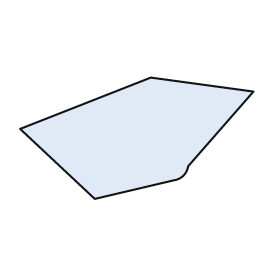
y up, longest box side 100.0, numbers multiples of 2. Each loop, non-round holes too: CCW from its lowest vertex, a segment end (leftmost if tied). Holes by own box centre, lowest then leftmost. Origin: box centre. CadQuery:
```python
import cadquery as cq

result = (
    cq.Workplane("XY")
    .moveTo(-18.0, -26.0)
    .lineTo(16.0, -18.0)
    .threePointArc((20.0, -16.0), (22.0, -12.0))
    .lineTo(50.0, 20.0)
    .lineTo(6.0, 26.0)
    .lineTo(-50.0, 4.0)
    .close()
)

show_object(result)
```